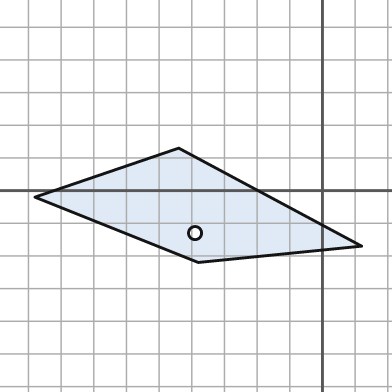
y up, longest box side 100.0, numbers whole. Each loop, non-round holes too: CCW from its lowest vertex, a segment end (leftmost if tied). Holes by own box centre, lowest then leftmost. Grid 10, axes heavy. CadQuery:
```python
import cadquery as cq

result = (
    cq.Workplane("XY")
    .moveTo(-38.0, -22.0)
    .lineTo(12.0, -17.0)
    .lineTo(-44.0, 13.0)
    .lineTo(-88.0, -2.0)
    .close()
    .moveTo(-39.0, -13.0)
    .circle(2.0)
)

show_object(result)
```